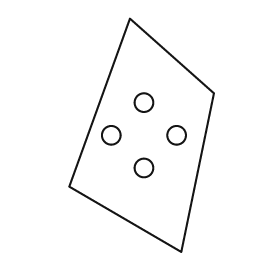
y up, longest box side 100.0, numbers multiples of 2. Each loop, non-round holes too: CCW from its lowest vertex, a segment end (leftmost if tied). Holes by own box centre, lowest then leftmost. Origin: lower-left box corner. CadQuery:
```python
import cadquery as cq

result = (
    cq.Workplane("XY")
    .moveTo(48.0, 0.0)
    .lineTo(62.0, 68.0)
    .lineTo(26.0, 100.0)
    .lineTo(0.0, 28.0)
    .close()
    .moveTo(32.0, 36.0)
    .circle(4.0)
    .moveTo(18.0, 50.0)
    .circle(4.0)
    .moveTo(46.0, 50.0)
    .circle(4.0)
    .moveTo(32.0, 64.0)
    .circle(4.0)
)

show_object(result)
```